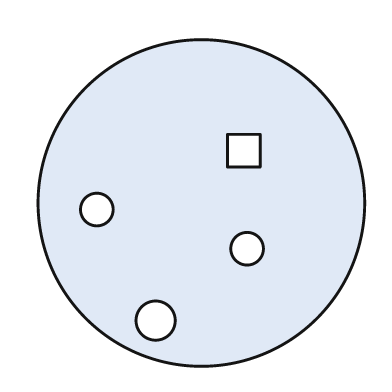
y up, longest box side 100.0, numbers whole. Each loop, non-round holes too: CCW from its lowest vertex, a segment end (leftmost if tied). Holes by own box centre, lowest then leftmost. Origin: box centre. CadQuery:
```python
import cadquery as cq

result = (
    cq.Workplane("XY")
    .moveTo(0.0, 0.0)
    .circle(50.0)
    .moveTo(-14.0, -36.0)
    .circle(6.0)
    .moveTo(14.0, -14.0)
    .circle(5.0)
    .moveTo(-32.0, -2.0)
    .circle(5.0)
    .moveTo(8.0, 11.0)
    .lineTo(18.0, 11.0)
    .lineTo(18.0, 21.0)
    .lineTo(8.0, 21.0)
    .close()
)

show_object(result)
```